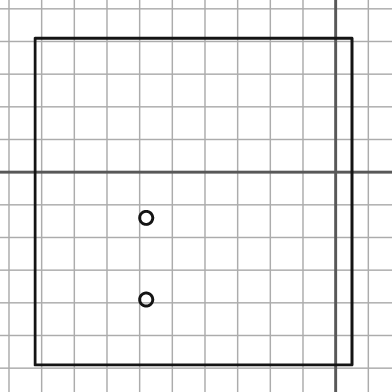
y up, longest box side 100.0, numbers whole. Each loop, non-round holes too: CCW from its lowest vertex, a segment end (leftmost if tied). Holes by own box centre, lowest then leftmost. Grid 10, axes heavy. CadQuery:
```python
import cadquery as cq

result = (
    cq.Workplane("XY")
    .moveTo(-92.0, -59.0)
    .lineTo(5.0, -59.0)
    .lineTo(5.0, 41.0)
    .lineTo(-92.0, 41.0)
    .close()
    .moveTo(-58.0, -39.0)
    .circle(2.0)
    .moveTo(-58.0, -14.0)
    .circle(2.0)
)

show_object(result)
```